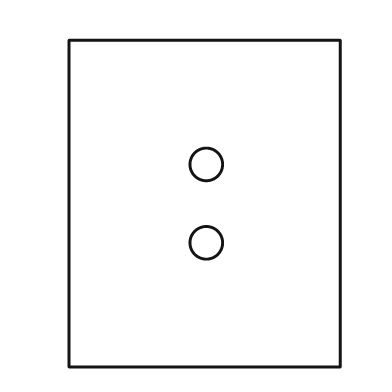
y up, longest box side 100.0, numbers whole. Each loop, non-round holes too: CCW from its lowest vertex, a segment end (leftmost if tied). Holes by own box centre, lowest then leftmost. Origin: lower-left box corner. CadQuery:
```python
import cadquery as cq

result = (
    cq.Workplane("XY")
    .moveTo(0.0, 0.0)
    .lineTo(83.0, 0.0)
    .lineTo(83.0, 100.0)
    .lineTo(0.0, 100.0)
    .close()
    .moveTo(42.0, 38.0)
    .circle(5.0)
    .moveTo(42.0, 62.0)
    .circle(5.0)
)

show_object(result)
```